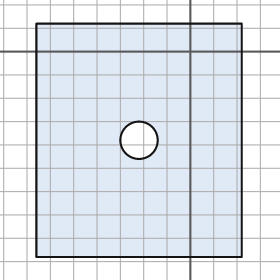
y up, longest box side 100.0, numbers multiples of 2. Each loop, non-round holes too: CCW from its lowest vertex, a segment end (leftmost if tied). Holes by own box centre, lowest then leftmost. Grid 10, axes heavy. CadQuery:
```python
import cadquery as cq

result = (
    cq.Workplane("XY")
    .moveTo(-66.0, -88.0)
    .lineTo(22.0, -88.0)
    .lineTo(22.0, 12.0)
    .lineTo(-66.0, 12.0)
    .close()
    .moveTo(-22.0, -38.0)
    .circle(8.0)
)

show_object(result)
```